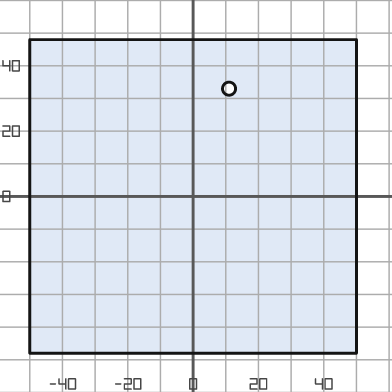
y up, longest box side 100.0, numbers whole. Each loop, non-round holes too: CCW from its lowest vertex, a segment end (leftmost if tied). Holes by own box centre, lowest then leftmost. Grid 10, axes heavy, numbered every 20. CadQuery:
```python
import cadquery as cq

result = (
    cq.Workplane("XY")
    .moveTo(-50.0, -48.0)
    .lineTo(50.0, -48.0)
    .lineTo(50.0, 48.0)
    .lineTo(-50.0, 48.0)
    .close()
    .moveTo(11.0, 33.0)
    .circle(2.0)
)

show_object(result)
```